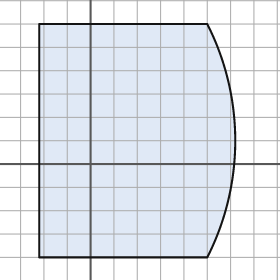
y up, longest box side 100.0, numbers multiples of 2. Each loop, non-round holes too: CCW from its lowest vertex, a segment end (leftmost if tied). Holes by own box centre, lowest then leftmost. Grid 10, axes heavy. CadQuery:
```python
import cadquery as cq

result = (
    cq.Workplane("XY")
    .moveTo(-22.0, -40.0)
    .lineTo(50.0, -40.0)
    .threePointArc((62.0, 10.0), (50.0, 60.0))
    .lineTo(-22.0, 60.0)
    .close()
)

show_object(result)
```